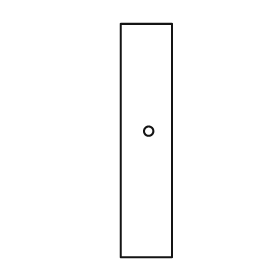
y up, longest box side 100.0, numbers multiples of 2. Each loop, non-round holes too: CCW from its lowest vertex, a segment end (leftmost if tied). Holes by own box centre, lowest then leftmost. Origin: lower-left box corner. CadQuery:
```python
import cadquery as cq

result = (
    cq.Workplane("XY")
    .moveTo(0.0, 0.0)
    .lineTo(22.0, 0.0)
    .lineTo(22.0, 100.0)
    .lineTo(0.0, 100.0)
    .close()
    .moveTo(12.0, 54.0)
    .circle(2.0)
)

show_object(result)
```